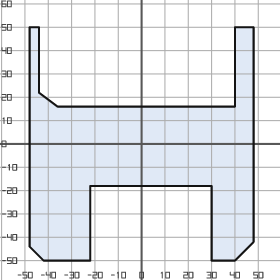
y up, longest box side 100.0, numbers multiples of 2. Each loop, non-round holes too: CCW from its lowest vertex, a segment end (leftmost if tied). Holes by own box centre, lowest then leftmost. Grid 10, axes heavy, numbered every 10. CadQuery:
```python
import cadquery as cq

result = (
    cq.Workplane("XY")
    .moveTo(-42.0, -50.0)
    .lineTo(-22.0, -50.0)
    .lineTo(-22.0, -18.0)
    .lineTo(30.0, -18.0)
    .lineTo(30.0, -50.0)
    .lineTo(40.0, -50.0)
    .lineTo(48.0, -42.0)
    .lineTo(48.0, 50.0)
    .lineTo(40.0, 50.0)
    .lineTo(40.0, 16.0)
    .lineTo(-36.0, 16.0)
    .lineTo(-44.0, 22.0)
    .lineTo(-44.0, 50.0)
    .lineTo(-48.0, 50.0)
    .lineTo(-48.0, -44.0)
    .close()
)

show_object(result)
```